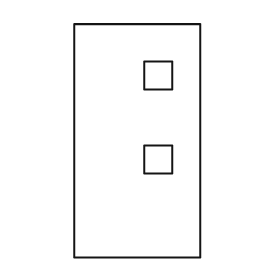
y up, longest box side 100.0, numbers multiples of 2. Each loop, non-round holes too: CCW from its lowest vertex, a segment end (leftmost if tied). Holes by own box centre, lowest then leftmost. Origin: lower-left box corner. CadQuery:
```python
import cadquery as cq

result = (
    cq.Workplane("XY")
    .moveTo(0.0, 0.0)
    .lineTo(54.0, 0.0)
    .lineTo(54.0, 100.0)
    .lineTo(0.0, 100.0)
    .close()
    .moveTo(30.0, 36.0)
    .lineTo(42.0, 36.0)
    .lineTo(42.0, 48.0)
    .lineTo(30.0, 48.0)
    .close()
    .moveTo(30.0, 72.0)
    .lineTo(42.0, 72.0)
    .lineTo(42.0, 84.0)
    .lineTo(30.0, 84.0)
    .close()
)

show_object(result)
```